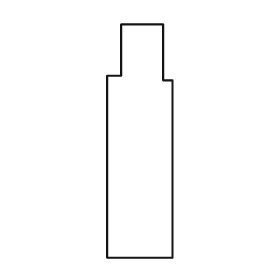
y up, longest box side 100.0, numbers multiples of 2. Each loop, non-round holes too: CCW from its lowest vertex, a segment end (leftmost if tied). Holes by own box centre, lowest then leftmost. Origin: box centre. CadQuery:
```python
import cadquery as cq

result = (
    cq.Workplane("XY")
    .moveTo(-14.0, -50.0)
    .lineTo(14.0, -50.0)
    .lineTo(14.0, 26.0)
    .lineTo(10.0, 26.0)
    .lineTo(10.0, 50.0)
    .lineTo(-8.0, 50.0)
    .lineTo(-8.0, 28.0)
    .lineTo(-14.0, 28.0)
    .close()
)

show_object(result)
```